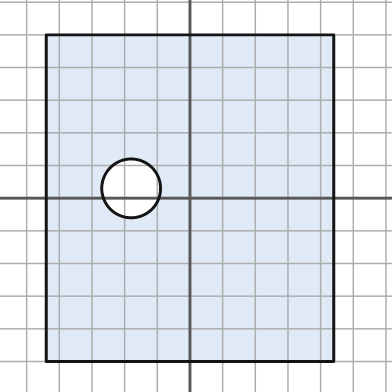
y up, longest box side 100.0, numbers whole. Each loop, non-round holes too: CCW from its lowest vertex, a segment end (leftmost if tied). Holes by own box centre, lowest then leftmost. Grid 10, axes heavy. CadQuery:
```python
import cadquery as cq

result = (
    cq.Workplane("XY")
    .moveTo(-44.0, -50.0)
    .lineTo(44.0, -50.0)
    .lineTo(44.0, 50.0)
    .lineTo(-44.0, 50.0)
    .close()
    .moveTo(-18.0, 3.0)
    .circle(9.0)
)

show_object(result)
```